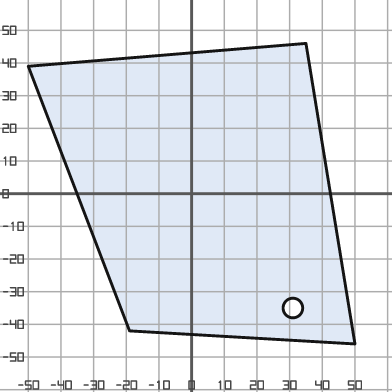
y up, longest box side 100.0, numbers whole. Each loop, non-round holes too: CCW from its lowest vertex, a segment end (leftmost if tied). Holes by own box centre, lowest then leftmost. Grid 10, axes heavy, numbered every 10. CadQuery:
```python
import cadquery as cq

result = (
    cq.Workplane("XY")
    .moveTo(50.0, -46.0)
    .lineTo(35.0, 46.0)
    .lineTo(-50.0, 39.0)
    .lineTo(-19.0, -42.0)
    .close()
    .moveTo(31.0, -35.0)
    .circle(3.0)
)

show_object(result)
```